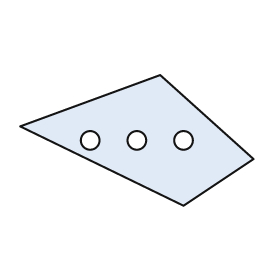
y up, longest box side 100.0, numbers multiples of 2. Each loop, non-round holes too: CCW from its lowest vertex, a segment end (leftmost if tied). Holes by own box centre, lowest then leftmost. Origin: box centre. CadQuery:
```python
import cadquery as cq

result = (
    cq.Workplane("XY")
    .moveTo(20.0, -28.0)
    .lineTo(50.0, -8.0)
    .lineTo(10.0, 28.0)
    .lineTo(-50.0, 6.0)
    .close()
    .moveTo(-20.0, 0.0)
    .circle(4.0)
    .moveTo(0.0, 0.0)
    .circle(4.0)
    .moveTo(20.0, 0.0)
    .circle(4.0)
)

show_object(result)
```